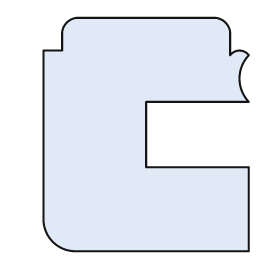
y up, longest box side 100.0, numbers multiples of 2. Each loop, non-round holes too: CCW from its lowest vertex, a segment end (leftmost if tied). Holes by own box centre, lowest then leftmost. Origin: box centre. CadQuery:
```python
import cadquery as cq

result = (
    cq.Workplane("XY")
    .moveTo(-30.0, -50.0)
    .lineTo(44.0, -50.0)
    .lineTo(44.0, -14.0)
    .lineTo(0.0, -14.0)
    .lineTo(0.0, 14.0)
    .lineTo(44.0, 14.0)
    .threePointArc((40.0, 24.0), (44.0, 34.0))
    .threePointArc((40.0, 36.0), (36.0, 34.0))
    .lineTo(36.0, 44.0)
    .threePointArc((34.0, 48.0), (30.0, 50.0))
    .lineTo(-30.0, 50.0)
    .threePointArc((-34.0, 48.0), (-36.0, 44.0))
    .lineTo(-36.0, 36.0)
    .lineTo(-44.0, 36.0)
    .lineTo(-44.0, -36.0)
    .threePointArc((-40.0, -46.0), (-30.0, -50.0))
    .close()
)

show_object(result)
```